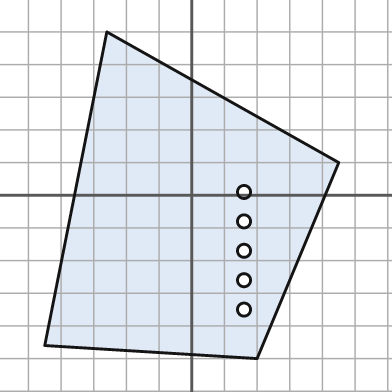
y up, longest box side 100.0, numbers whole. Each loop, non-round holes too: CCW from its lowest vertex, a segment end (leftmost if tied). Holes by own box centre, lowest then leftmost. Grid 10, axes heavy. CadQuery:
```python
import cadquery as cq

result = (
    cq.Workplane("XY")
    .moveTo(20.0, -50.0)
    .lineTo(45.0, 10.0)
    .lineTo(-26.0, 50.0)
    .lineTo(-45.0, -46.0)
    .close()
    .moveTo(16.0, -35.0)
    .circle(2.0)
    .moveTo(16.0, -26.0)
    .circle(2.0)
    .moveTo(16.0, -17.0)
    .circle(2.0)
    .moveTo(16.0, -8.0)
    .circle(2.0)
    .moveTo(16.0, 1.0)
    .circle(2.0)
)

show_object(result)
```